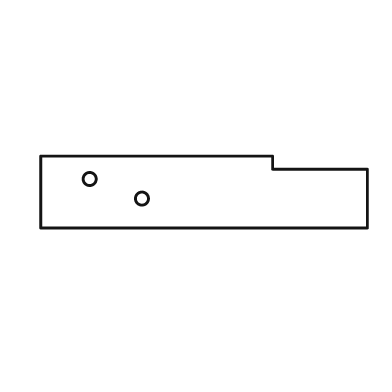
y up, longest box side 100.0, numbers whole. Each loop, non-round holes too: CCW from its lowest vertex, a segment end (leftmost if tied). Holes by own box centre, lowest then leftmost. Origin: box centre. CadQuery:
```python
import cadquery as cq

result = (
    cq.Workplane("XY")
    .moveTo(-50.0, -11.0)
    .lineTo(50.0, -11.0)
    .lineTo(50.0, 7.0)
    .lineTo(21.0, 7.0)
    .lineTo(21.0, 11.0)
    .lineTo(-50.0, 11.0)
    .close()
    .moveTo(-19.0, -2.0)
    .circle(2.0)
    .moveTo(-35.0, 4.0)
    .circle(2.0)
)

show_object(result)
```